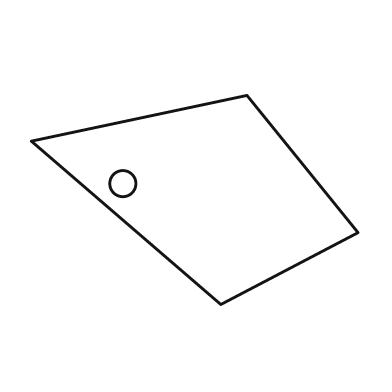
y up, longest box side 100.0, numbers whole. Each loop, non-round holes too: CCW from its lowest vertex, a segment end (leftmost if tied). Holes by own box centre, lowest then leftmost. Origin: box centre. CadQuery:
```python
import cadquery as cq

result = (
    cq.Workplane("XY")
    .moveTo(8.0, -32.0)
    .lineTo(50.0, -10.0)
    .lineTo(16.0, 32.0)
    .lineTo(-50.0, 18.0)
    .close()
    .moveTo(-22.0, 5.0)
    .circle(4.0)
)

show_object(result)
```